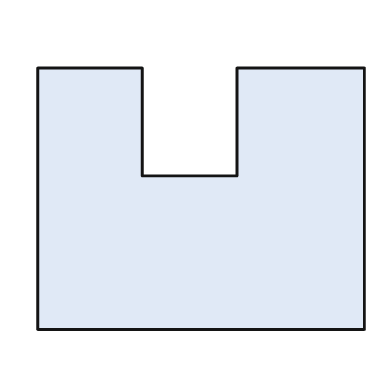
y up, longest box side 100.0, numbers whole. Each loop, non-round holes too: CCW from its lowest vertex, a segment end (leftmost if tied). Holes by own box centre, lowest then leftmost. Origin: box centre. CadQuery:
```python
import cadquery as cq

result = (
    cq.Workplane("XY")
    .moveTo(-50.0, -40.0)
    .lineTo(50.0, -40.0)
    .lineTo(50.0, 40.0)
    .lineTo(11.0, 40.0)
    .lineTo(11.0, 7.0)
    .lineTo(-18.0, 7.0)
    .lineTo(-18.0, 40.0)
    .lineTo(-50.0, 40.0)
    .close()
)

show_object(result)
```